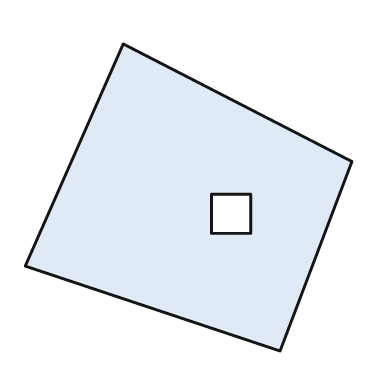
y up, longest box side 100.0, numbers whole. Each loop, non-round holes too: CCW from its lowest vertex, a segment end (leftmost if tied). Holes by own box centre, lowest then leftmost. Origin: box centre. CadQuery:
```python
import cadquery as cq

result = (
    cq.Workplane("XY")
    .moveTo(28.0, -47.0)
    .lineTo(50.0, 11.0)
    .lineTo(-20.0, 47.0)
    .lineTo(-50.0, -21.0)
    .close()
    .moveTo(7.0, -11.0)
    .lineTo(19.0, -11.0)
    .lineTo(19.0, 1.0)
    .lineTo(7.0, 1.0)
    .close()
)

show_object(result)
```